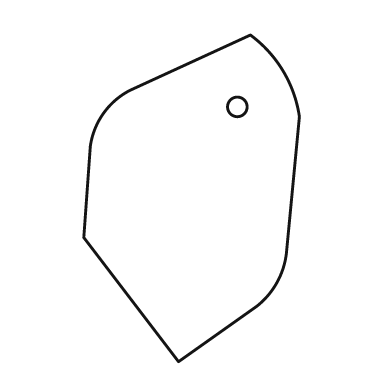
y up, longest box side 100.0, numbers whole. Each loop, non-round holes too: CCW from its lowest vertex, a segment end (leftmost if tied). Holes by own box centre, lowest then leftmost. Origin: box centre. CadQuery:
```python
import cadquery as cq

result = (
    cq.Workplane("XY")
    .moveTo(-4.0, -50.0)
    .lineTo(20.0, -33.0)
    .threePointArc((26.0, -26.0), (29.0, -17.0))
    .lineTo(33.0, 25.0)
    .threePointArc((28.0, 39.0), (18.0, 50.0))
    .lineTo(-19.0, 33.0)
    .threePointArc((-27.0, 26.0), (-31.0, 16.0))
    .lineTo(-33.0, -12.0)
    .close()
    .moveTo(14.0, 28.0)
    .circle(3.0)
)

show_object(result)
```